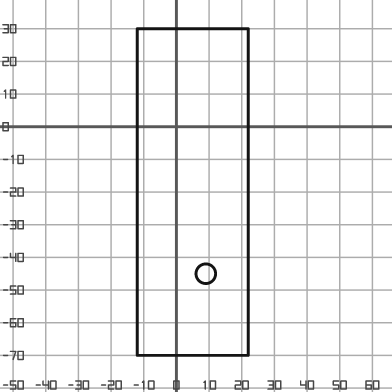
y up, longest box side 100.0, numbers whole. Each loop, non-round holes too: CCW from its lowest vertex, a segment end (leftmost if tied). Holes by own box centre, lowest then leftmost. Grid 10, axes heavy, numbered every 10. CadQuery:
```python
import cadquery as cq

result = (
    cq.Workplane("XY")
    .moveTo(-12.0, -70.0)
    .lineTo(22.0, -70.0)
    .lineTo(22.0, 30.0)
    .lineTo(-12.0, 30.0)
    .close()
    .moveTo(9.0, -45.0)
    .circle(3.0)
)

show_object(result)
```